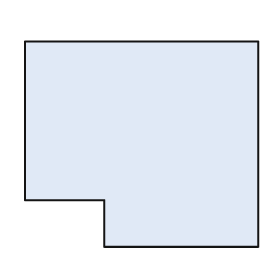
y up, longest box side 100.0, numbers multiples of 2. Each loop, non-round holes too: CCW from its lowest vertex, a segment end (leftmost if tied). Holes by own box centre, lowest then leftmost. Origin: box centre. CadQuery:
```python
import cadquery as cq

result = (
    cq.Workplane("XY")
    .moveTo(-16.0, -44.0)
    .lineTo(50.0, -44.0)
    .lineTo(50.0, 44.0)
    .lineTo(-50.0, 44.0)
    .lineTo(-50.0, -24.0)
    .lineTo(-16.0, -24.0)
    .close()
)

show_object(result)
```